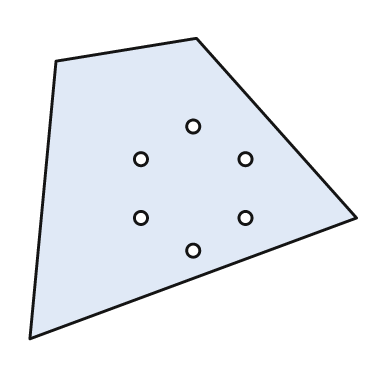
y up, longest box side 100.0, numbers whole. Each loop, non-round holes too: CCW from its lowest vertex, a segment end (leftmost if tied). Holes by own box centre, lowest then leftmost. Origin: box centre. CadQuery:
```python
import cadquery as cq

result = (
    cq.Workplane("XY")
    .moveTo(-50.0, -46.0)
    .lineTo(50.0, -9.0)
    .lineTo(1.0, 46.0)
    .lineTo(-42.0, 39.0)
    .close()
    .moveTo(0.0, -19.0)
    .circle(2.0)
    .moveTo(-16.0, -9.0)
    .circle(2.0)
    .moveTo(16.0, -9.0)
    .circle(2.0)
    .moveTo(-16.0, 9.0)
    .circle(2.0)
    .moveTo(16.0, 9.0)
    .circle(2.0)
    .moveTo(0.0, 19.0)
    .circle(2.0)
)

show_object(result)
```